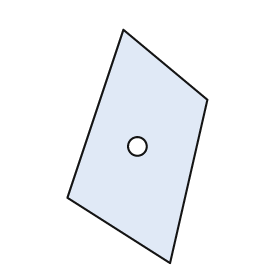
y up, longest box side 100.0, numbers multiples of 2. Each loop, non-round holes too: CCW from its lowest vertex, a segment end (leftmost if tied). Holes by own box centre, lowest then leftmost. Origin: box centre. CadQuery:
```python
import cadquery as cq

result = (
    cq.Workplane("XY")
    .moveTo(14.0, -50.0)
    .lineTo(30.0, 20.0)
    .lineTo(-6.0, 50.0)
    .lineTo(-30.0, -22.0)
    .close()
    .moveTo(0.0, 0.0)
    .circle(4.0)
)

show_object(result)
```